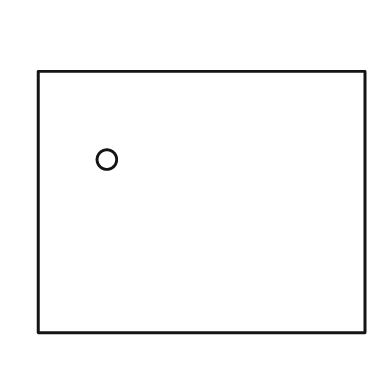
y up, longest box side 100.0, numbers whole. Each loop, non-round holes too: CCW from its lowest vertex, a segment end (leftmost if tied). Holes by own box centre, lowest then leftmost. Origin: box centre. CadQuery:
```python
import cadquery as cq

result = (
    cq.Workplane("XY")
    .moveTo(-50.0, -40.0)
    .lineTo(50.0, -40.0)
    .lineTo(50.0, 40.0)
    .lineTo(-50.0, 40.0)
    .close()
    .moveTo(-29.0, 13.0)
    .circle(3.0)
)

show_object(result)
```